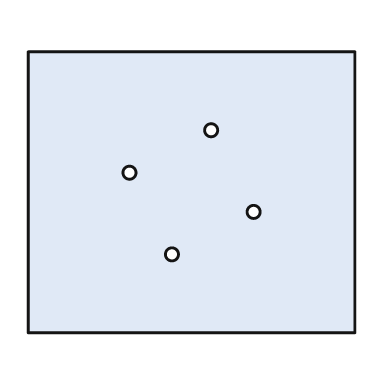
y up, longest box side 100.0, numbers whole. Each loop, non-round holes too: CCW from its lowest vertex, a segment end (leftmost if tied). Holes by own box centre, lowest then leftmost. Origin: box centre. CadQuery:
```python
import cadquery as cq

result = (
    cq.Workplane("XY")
    .moveTo(-50.0, -43.0)
    .lineTo(50.0, -43.0)
    .lineTo(50.0, 43.0)
    .lineTo(-50.0, 43.0)
    .close()
    .moveTo(-6.0, -19.0)
    .circle(2.0)
    .moveTo(19.0, -6.0)
    .circle(2.0)
    .moveTo(-19.0, 6.0)
    .circle(2.0)
    .moveTo(6.0, 19.0)
    .circle(2.0)
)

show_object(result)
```